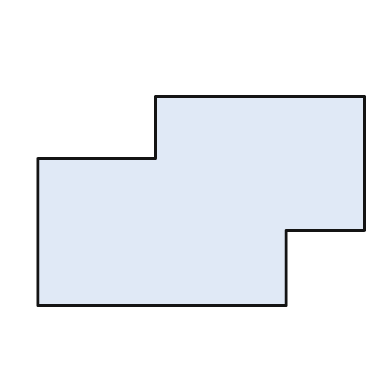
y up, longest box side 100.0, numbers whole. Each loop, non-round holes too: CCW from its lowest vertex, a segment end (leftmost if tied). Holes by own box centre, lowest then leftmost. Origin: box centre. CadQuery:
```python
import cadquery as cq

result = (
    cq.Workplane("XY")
    .moveTo(-50.0, -32.0)
    .lineTo(26.0, -32.0)
    .lineTo(26.0, -9.0)
    .lineTo(50.0, -9.0)
    .lineTo(50.0, 32.0)
    .lineTo(-14.0, 32.0)
    .lineTo(-14.0, 13.0)
    .lineTo(-50.0, 13.0)
    .close()
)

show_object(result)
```